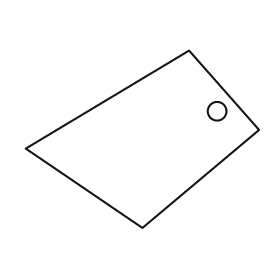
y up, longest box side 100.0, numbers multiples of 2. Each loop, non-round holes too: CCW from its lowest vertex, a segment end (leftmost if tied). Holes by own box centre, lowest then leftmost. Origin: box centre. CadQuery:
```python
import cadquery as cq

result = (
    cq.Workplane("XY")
    .moveTo(0.0, -38.0)
    .lineTo(50.0, 4.0)
    .lineTo(20.0, 38.0)
    .lineTo(-50.0, -4.0)
    .close()
    .moveTo(32.0, 12.0)
    .circle(4.0)
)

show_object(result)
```